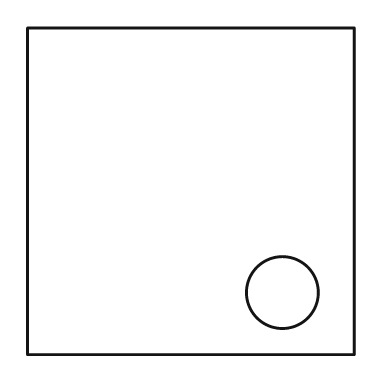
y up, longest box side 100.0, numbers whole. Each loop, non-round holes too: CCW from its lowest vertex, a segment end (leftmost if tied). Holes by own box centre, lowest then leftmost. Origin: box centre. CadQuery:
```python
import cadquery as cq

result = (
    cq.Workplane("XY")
    .moveTo(-50.0, -50.0)
    .lineTo(50.0, -50.0)
    .lineTo(50.0, 50.0)
    .lineTo(-50.0, 50.0)
    .close()
    .moveTo(28.0, -31.0)
    .circle(11.0)
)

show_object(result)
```